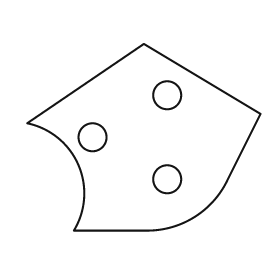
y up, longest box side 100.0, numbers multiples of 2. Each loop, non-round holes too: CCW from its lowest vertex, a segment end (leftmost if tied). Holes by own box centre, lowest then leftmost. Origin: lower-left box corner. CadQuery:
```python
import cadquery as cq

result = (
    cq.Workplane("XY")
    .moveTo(20.0, 0.0)
    .lineTo(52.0, 0.0)
    .threePointArc((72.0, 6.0), (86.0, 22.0))
    .lineTo(100.0, 50.0)
    .lineTo(50.0, 80.0)
    .lineTo(0.0, 46.0)
    .threePointArc((22.0, 28.0), (20.0, 0.0))
    .close()
    .moveTo(60.0, 22.0)
    .circle(6.0)
    .moveTo(28.0, 40.0)
    .circle(6.0)
    .moveTo(60.0, 58.0)
    .circle(6.0)
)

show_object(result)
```